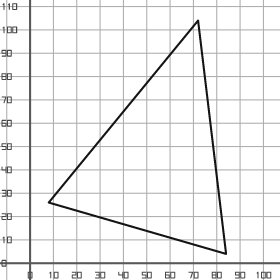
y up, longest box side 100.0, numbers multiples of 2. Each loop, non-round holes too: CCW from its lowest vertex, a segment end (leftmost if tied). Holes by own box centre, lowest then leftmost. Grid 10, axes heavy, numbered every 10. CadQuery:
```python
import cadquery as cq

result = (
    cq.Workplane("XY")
    .moveTo(84.0, 4.0)
    .lineTo(72.0, 104.0)
    .lineTo(8.0, 26.0)
    .close()
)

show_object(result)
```